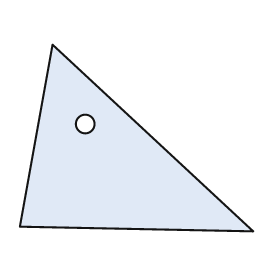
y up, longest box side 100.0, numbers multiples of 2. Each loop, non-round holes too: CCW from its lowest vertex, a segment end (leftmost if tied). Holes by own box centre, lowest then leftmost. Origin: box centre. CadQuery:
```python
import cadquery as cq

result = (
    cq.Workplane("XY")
    .moveTo(50.0, -40.0)
    .lineTo(-36.0, 40.0)
    .lineTo(-50.0, -38.0)
    .close()
    .moveTo(-22.0, 6.0)
    .circle(4.0)
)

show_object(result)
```